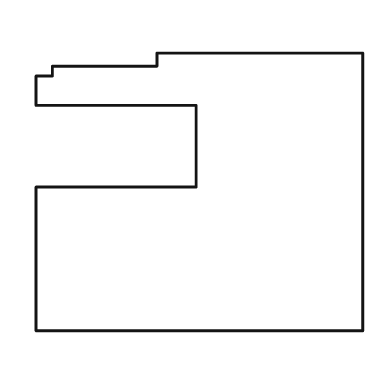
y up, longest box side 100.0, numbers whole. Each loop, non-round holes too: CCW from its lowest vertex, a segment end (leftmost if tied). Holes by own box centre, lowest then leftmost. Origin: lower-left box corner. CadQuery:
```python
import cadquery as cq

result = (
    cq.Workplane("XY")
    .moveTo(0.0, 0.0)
    .lineTo(100.0, 0.0)
    .lineTo(100.0, 85.0)
    .lineTo(37.0, 85.0)
    .lineTo(37.0, 81.0)
    .lineTo(5.0, 81.0)
    .lineTo(5.0, 78.0)
    .lineTo(0.0, 78.0)
    .lineTo(0.0, 69.0)
    .lineTo(49.0, 69.0)
    .lineTo(49.0, 44.0)
    .lineTo(0.0, 44.0)
    .close()
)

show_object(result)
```